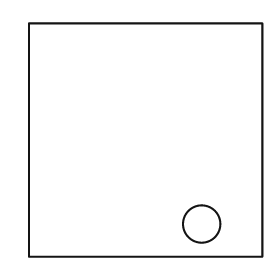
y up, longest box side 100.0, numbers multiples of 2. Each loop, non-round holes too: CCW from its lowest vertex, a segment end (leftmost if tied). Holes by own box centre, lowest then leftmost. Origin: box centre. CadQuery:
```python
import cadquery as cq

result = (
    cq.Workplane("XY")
    .moveTo(-50.0, -50.0)
    .lineTo(50.0, -50.0)
    .lineTo(50.0, 50.0)
    .lineTo(-50.0, 50.0)
    .close()
    .moveTo(24.0, -36.0)
    .circle(8.0)
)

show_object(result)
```